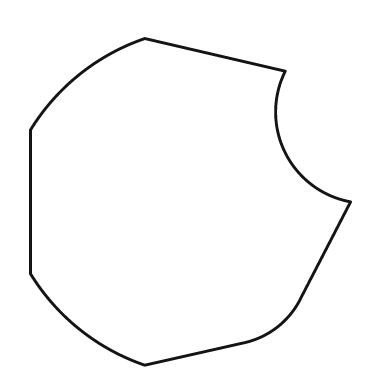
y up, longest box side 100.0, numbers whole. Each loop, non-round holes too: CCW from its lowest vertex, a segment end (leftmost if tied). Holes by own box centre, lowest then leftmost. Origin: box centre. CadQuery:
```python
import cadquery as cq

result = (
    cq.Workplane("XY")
    .moveTo(-14.0, -50.0)
    .lineTo(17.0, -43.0)
    .threePointArc((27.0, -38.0), (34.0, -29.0))
    .lineTo(49.0, 0.0)
    .threePointArc((29.0, 15.0), (29.0, 40.0))
    .lineTo(-14.0, 50.0)
    .threePointArc((-34.0, 39.0), (-49.0, 22.0))
    .lineTo(-49.0, -22.0)
    .threePointArc((-34.0, -39.0), (-14.0, -50.0))
    .close()
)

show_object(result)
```